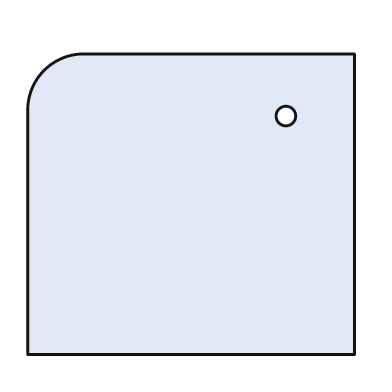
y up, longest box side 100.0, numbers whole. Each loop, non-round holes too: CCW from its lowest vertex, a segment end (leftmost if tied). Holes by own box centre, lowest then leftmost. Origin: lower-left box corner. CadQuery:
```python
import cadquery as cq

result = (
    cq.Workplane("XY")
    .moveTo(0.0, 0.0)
    .lineTo(100.0, 0.0)
    .lineTo(100.0, 92.0)
    .lineTo(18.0, 92.0)
    .threePointArc((5.0, 87.0), (0.0, 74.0))
    .close()
    .moveTo(79.0, 73.0)
    .circle(3.0)
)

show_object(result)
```